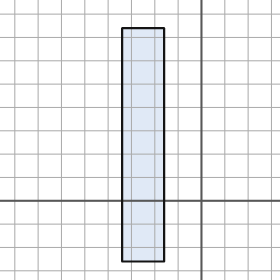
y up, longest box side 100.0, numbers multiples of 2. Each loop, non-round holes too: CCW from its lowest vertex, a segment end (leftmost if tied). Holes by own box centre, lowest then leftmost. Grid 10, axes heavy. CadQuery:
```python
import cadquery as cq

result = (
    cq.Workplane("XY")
    .moveTo(-34.0, -26.0)
    .lineTo(-16.0, -26.0)
    .lineTo(-16.0, 74.0)
    .lineTo(-34.0, 74.0)
    .close()
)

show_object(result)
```